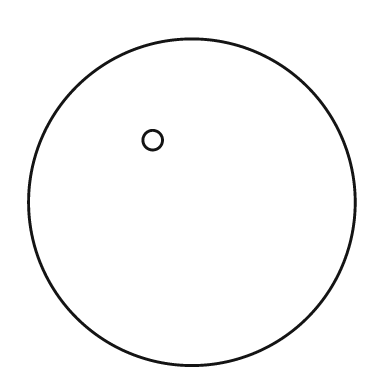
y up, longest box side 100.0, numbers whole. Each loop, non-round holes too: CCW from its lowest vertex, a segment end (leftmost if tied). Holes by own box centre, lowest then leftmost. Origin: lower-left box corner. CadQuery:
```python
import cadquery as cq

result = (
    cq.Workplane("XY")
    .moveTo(50.0, 50.0)
    .circle(50.0)
    .moveTo(38.0, 69.0)
    .circle(3.0)
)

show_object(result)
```